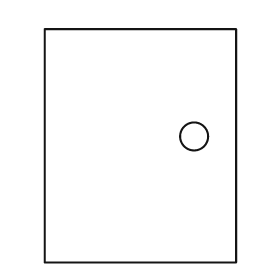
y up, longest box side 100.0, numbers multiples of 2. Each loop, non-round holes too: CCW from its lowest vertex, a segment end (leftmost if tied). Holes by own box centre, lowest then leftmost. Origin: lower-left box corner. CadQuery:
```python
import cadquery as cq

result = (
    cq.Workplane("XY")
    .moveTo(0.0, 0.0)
    .lineTo(82.0, 0.0)
    .lineTo(82.0, 100.0)
    .lineTo(0.0, 100.0)
    .close()
    .moveTo(64.0, 54.0)
    .circle(6.0)
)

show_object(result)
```